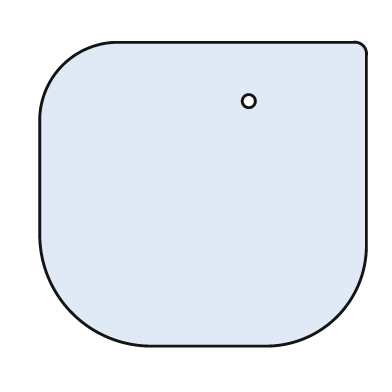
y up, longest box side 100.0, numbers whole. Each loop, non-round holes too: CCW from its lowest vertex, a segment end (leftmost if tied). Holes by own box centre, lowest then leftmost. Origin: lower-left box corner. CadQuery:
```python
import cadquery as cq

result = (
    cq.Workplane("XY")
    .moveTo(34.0, 0.0)
    .lineTo(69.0, 0.0)
    .threePointArc((91.0, 9.0), (100.0, 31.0))
    .lineTo(100.0, 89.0)
    .threePointArc((99.0, 92.0), (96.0, 93.0))
    .lineTo(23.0, 93.0)
    .threePointArc((7.0, 86.0), (0.0, 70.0))
    .lineTo(0.0, 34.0)
    .threePointArc((10.0, 10.0), (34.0, 0.0))
    .close()
    .moveTo(64.0, 75.0)
    .circle(2.0)
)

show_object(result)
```